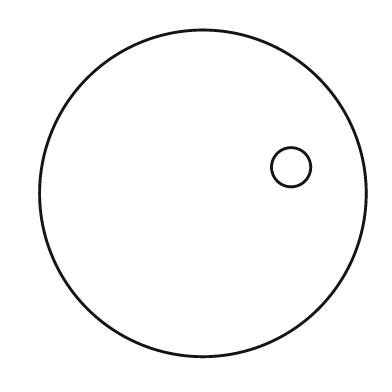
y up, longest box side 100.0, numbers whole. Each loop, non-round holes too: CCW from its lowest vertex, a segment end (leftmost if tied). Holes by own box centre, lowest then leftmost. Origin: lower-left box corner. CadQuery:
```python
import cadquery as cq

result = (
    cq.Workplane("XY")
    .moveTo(50.0, 50.0)
    .circle(50.0)
    .moveTo(77.0, 58.0)
    .circle(6.0)
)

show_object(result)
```